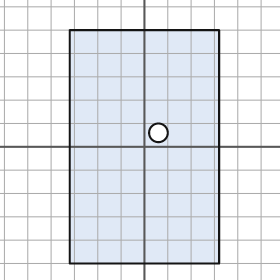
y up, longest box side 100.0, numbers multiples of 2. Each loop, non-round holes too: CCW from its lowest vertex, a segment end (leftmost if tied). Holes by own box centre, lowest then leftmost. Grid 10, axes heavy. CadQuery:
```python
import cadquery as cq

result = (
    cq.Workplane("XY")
    .moveTo(-32.0, -50.0)
    .lineTo(32.0, -50.0)
    .lineTo(32.0, 50.0)
    .lineTo(-32.0, 50.0)
    .close()
    .moveTo(6.0, 6.0)
    .circle(4.0)
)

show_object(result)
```